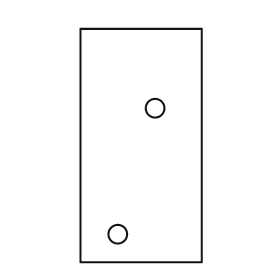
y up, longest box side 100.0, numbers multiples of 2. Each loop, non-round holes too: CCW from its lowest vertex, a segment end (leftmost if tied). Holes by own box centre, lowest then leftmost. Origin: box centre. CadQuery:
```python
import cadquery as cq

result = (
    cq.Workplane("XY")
    .moveTo(-26.0, -50.0)
    .lineTo(26.0, -50.0)
    .lineTo(26.0, 50.0)
    .lineTo(-26.0, 50.0)
    .close()
    .moveTo(-10.0, -38.0)
    .circle(4.0)
    .moveTo(6.0, 16.0)
    .circle(4.0)
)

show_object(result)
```